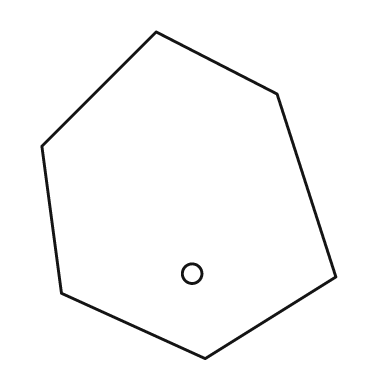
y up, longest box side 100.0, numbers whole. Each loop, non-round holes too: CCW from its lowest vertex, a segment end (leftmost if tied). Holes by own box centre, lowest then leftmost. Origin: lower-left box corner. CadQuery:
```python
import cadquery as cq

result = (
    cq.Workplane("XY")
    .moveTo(50.0, 0.0)
    .lineTo(90.0, 25.0)
    .lineTo(72.0, 81.0)
    .lineTo(35.0, 100.0)
    .lineTo(0.0, 65.0)
    .lineTo(6.0, 20.0)
    .close()
    .moveTo(46.0, 26.0)
    .circle(3.0)
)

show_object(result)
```